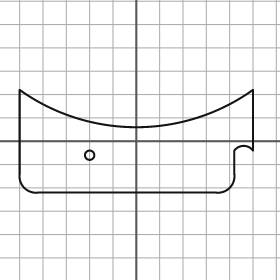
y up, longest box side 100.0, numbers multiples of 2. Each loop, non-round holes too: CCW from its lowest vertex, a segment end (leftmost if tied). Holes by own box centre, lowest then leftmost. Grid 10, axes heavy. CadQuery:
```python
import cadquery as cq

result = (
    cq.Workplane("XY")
    .moveTo(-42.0, -22.0)
    .lineTo(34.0, -22.0)
    .threePointArc((40.0, -20.0), (42.0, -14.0))
    .lineTo(42.0, -4.0)
    .threePointArc((46.0, -2.0), (50.0, -4.0))
    .lineTo(50.0, 22.0)
    .threePointArc((0.0, 6.0), (-50.0, 22.0))
    .lineTo(-50.0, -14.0)
    .threePointArc((-48.0, -20.0), (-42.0, -22.0))
    .close()
    .moveTo(-20.0, -6.0)
    .circle(2.0)
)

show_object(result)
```